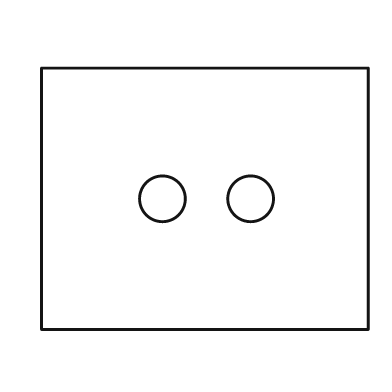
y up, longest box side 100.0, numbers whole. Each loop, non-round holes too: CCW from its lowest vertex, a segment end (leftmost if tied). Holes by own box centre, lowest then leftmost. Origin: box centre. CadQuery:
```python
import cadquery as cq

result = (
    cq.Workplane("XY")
    .moveTo(-50.0, -40.0)
    .lineTo(50.0, -40.0)
    .lineTo(50.0, 40.0)
    .lineTo(-50.0, 40.0)
    .close()
    .moveTo(-13.0, 0.0)
    .circle(7.0)
    .moveTo(14.0, 0.0)
    .circle(7.0)
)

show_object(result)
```